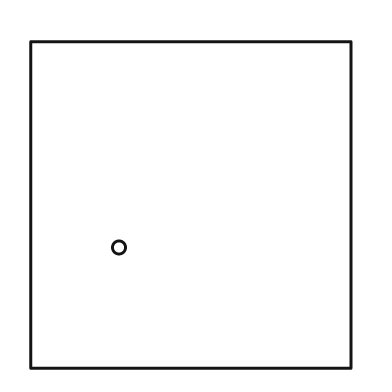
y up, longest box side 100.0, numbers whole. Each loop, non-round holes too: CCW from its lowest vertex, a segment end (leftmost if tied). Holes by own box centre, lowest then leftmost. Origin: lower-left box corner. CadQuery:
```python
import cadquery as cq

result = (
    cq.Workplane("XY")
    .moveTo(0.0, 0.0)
    .lineTo(98.0, 0.0)
    .lineTo(98.0, 100.0)
    .lineTo(0.0, 100.0)
    .close()
    .moveTo(27.0, 37.0)
    .circle(2.0)
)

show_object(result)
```